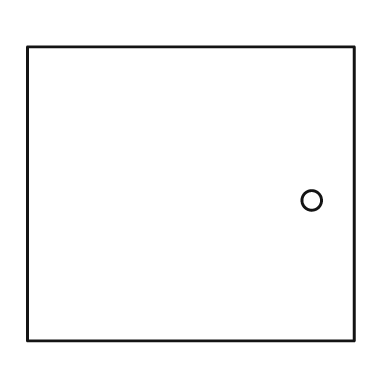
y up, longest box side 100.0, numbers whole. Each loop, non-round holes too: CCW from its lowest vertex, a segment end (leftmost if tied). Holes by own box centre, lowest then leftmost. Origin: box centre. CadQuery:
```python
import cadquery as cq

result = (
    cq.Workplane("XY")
    .moveTo(-50.0, -45.0)
    .lineTo(50.0, -45.0)
    .lineTo(50.0, 45.0)
    .lineTo(-50.0, 45.0)
    .close()
    .moveTo(37.0, -2.0)
    .circle(3.0)
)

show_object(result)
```